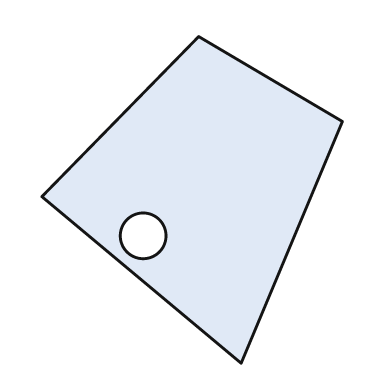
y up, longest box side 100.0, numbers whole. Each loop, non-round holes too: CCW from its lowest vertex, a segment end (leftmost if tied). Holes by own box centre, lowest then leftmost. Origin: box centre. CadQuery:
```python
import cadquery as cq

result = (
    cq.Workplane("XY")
    .moveTo(15.0, -50.0)
    .lineTo(46.0, 24.0)
    .lineTo(2.0, 50.0)
    .lineTo(-46.0, 1.0)
    .close()
    .moveTo(-15.0, -11.0)
    .circle(7.0)
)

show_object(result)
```